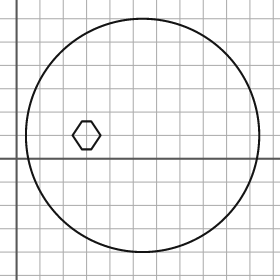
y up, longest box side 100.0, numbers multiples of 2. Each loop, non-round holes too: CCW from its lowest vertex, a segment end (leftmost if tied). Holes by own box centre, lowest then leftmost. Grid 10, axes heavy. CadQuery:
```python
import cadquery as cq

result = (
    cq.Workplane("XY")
    .moveTo(54.0, 10.0)
    .circle(50.0)
    .moveTo(28.0, 4.0)
    .lineTo(32.0, 4.0)
    .lineTo(36.0, 10.0)
    .lineTo(32.0, 16.0)
    .lineTo(28.0, 16.0)
    .lineTo(24.0, 10.0)
    .close()
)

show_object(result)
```